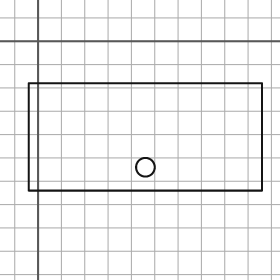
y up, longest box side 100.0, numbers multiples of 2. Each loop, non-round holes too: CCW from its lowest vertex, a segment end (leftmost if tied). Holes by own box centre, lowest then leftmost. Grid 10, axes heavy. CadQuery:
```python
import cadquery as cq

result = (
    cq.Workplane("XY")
    .moveTo(-4.0, -64.0)
    .lineTo(96.0, -64.0)
    .lineTo(96.0, -18.0)
    .lineTo(-4.0, -18.0)
    .close()
    .moveTo(46.0, -54.0)
    .circle(4.0)
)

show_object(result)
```